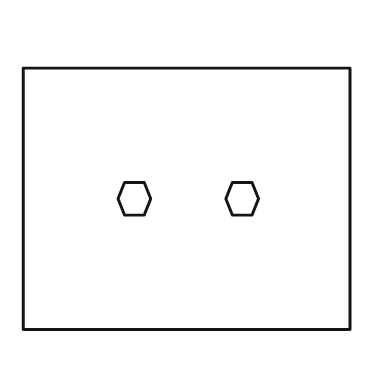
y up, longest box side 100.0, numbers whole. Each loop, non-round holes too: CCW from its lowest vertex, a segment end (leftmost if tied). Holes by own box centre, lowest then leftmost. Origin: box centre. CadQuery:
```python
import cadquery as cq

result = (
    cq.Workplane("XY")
    .moveTo(-50.0, -40.0)
    .lineTo(50.0, -40.0)
    .lineTo(50.0, 40.0)
    .lineTo(-50.0, 40.0)
    .close()
    .moveTo(-19.0, -5.0)
    .lineTo(-13.0, -5.0)
    .lineTo(-11.0, 0.0)
    .lineTo(-13.0, 5.0)
    .lineTo(-19.0, 5.0)
    .lineTo(-21.0, 0.0)
    .close()
    .moveTo(14.0, -5.0)
    .lineTo(20.0, -5.0)
    .lineTo(22.0, 0.0)
    .lineTo(20.0, 5.0)
    .lineTo(14.0, 5.0)
    .lineTo(12.0, 0.0)
    .close()
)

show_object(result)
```